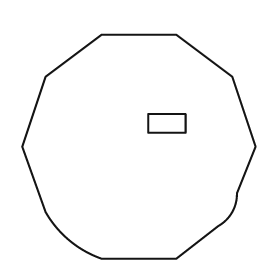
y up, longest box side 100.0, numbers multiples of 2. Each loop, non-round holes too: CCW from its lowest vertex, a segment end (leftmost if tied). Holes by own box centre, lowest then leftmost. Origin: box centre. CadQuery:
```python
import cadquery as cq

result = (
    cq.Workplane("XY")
    .moveTo(-16.0, -48.0)
    .lineTo(16.0, -48.0)
    .lineTo(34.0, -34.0)
    .threePointArc((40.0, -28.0), (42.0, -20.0))
    .lineTo(50.0, 0.0)
    .lineTo(40.0, 30.0)
    .lineTo(16.0, 48.0)
    .lineTo(-16.0, 48.0)
    .lineTo(-40.0, 30.0)
    .lineTo(-50.0, 0.0)
    .lineTo(-40.0, -28.0)
    .threePointArc((-30.0, -40.0), (-16.0, -48.0))
    .close()
    .moveTo(4.0, 6.0)
    .lineTo(20.0, 6.0)
    .lineTo(20.0, 14.0)
    .lineTo(4.0, 14.0)
    .close()
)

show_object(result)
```